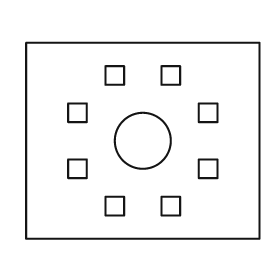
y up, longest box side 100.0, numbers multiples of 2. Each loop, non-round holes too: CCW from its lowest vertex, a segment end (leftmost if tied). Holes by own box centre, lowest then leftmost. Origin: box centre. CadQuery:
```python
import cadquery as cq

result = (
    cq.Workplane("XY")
    .moveTo(-50.0, -42.0)
    .lineTo(50.0, -42.0)
    .lineTo(50.0, 42.0)
    .lineTo(-50.0, 42.0)
    .close()
    .moveTo(-16.0, -32.0)
    .lineTo(-8.0, -32.0)
    .lineTo(-8.0, -24.0)
    .lineTo(-16.0, -24.0)
    .close()
    .moveTo(8.0, -32.0)
    .lineTo(16.0, -32.0)
    .lineTo(16.0, -24.0)
    .lineTo(8.0, -24.0)
    .close()
    .moveTo(-32.0, -16.0)
    .lineTo(-24.0, -16.0)
    .lineTo(-24.0, -8.0)
    .lineTo(-32.0, -8.0)
    .close()
    .moveTo(24.0, -16.0)
    .lineTo(32.0, -16.0)
    .lineTo(32.0, -8.0)
    .lineTo(24.0, -8.0)
    .close()
    .moveTo(0.0, 0.0)
    .circle(12.0)
    .moveTo(-32.0, 8.0)
    .lineTo(-24.0, 8.0)
    .lineTo(-24.0, 16.0)
    .lineTo(-32.0, 16.0)
    .close()
    .moveTo(24.0, 8.0)
    .lineTo(32.0, 8.0)
    .lineTo(32.0, 16.0)
    .lineTo(24.0, 16.0)
    .close()
    .moveTo(-16.0, 24.0)
    .lineTo(-8.0, 24.0)
    .lineTo(-8.0, 32.0)
    .lineTo(-16.0, 32.0)
    .close()
    .moveTo(8.0, 24.0)
    .lineTo(16.0, 24.0)
    .lineTo(16.0, 32.0)
    .lineTo(8.0, 32.0)
    .close()
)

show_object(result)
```